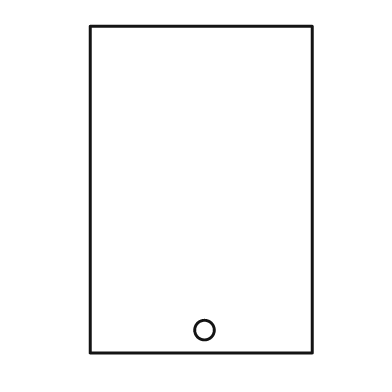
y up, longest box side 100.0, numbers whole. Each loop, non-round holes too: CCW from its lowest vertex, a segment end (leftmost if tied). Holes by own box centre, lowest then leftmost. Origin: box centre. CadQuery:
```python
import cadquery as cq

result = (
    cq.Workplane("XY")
    .moveTo(-34.0, -50.0)
    .lineTo(34.0, -50.0)
    .lineTo(34.0, 50.0)
    .lineTo(-34.0, 50.0)
    .close()
    .moveTo(1.0, -43.0)
    .circle(3.0)
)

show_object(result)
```